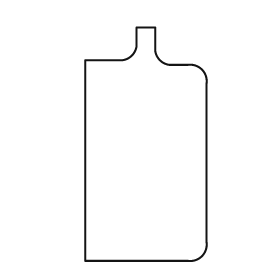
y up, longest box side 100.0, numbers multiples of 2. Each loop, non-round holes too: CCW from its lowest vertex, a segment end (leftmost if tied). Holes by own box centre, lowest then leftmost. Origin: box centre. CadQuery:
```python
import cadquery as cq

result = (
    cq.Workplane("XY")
    .moveTo(-26.0, -50.0)
    .lineTo(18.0, -50.0)
    .threePointArc((24.0, -48.0), (26.0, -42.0))
    .lineTo(26.0, 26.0)
    .threePointArc((24.0, 32.0), (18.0, 34.0))
    .lineTo(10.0, 34.0)
    .threePointArc((6.0, 36.0), (4.0, 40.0))
    .lineTo(4.0, 50.0)
    .lineTo(-4.0, 50.0)
    .lineTo(-4.0, 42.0)
    .threePointArc((-6.0, 38.0), (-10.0, 36.0))
    .lineTo(-26.0, 36.0)
    .close()
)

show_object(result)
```